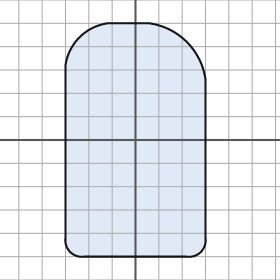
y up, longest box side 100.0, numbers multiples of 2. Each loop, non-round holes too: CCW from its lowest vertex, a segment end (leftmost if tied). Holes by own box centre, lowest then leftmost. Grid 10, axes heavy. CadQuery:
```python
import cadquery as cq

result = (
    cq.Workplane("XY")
    .moveTo(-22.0, -50.0)
    .lineTo(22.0, -50.0)
    .threePointArc((28.0, -48.0), (30.0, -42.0))
    .lineTo(30.0, 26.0)
    .threePointArc((22.0, 42.0), (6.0, 50.0))
    .lineTo(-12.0, 50.0)
    .threePointArc((-24.0, 44.0), (-30.0, 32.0))
    .lineTo(-30.0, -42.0)
    .threePointArc((-28.0, -48.0), (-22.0, -50.0))
    .close()
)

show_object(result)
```